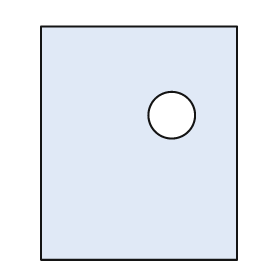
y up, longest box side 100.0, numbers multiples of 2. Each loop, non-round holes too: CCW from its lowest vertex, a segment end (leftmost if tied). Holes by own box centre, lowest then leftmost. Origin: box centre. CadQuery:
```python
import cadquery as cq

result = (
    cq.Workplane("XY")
    .moveTo(-42.0, -50.0)
    .lineTo(42.0, -50.0)
    .lineTo(42.0, 50.0)
    .lineTo(-42.0, 50.0)
    .close()
    .moveTo(14.0, 12.0)
    .circle(10.0)
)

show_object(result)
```